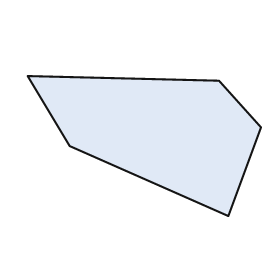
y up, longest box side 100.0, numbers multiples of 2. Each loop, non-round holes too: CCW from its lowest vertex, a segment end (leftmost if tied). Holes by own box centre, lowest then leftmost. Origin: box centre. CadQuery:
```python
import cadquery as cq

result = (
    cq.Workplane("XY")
    .moveTo(36.0, -30.0)
    .lineTo(50.0, 8.0)
    .lineTo(32.0, 28.0)
    .lineTo(-50.0, 30.0)
    .lineTo(-32.0, 0.0)
    .close()
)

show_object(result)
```